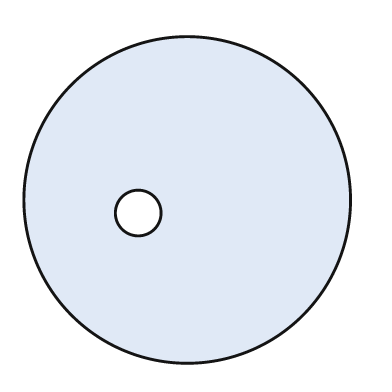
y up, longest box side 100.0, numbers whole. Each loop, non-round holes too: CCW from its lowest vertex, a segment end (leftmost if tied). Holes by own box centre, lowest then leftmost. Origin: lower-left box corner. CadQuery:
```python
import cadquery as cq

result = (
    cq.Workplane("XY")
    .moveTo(50.0, 50.0)
    .circle(50.0)
    .moveTo(35.0, 46.0)
    .circle(7.0)
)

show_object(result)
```